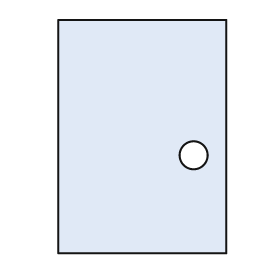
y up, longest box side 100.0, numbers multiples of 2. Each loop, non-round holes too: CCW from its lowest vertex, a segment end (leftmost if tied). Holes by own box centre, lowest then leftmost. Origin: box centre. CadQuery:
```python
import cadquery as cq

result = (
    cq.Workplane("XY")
    .moveTo(-36.0, -50.0)
    .lineTo(36.0, -50.0)
    .lineTo(36.0, 50.0)
    .lineTo(-36.0, 50.0)
    .close()
    .moveTo(22.0, -8.0)
    .circle(6.0)
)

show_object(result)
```